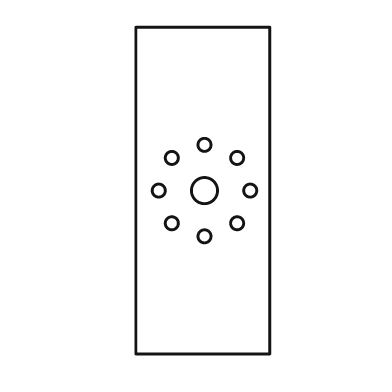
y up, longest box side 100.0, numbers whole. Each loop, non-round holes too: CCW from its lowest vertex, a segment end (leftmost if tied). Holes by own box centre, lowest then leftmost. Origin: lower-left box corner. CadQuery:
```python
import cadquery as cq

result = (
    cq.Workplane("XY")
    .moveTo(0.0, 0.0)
    .lineTo(41.0, 0.0)
    .lineTo(41.0, 100.0)
    .lineTo(0.0, 100.0)
    .close()
    .moveTo(21.0, 36.0)
    .circle(2.0)
    .moveTo(11.0, 40.0)
    .circle(2.0)
    .moveTo(31.0, 40.0)
    .circle(2.0)
    .moveTo(7.0, 50.0)
    .circle(2.0)
    .moveTo(21.0, 50.0)
    .circle(4.0)
    .moveTo(35.0, 50.0)
    .circle(2.0)
    .moveTo(11.0, 60.0)
    .circle(2.0)
    .moveTo(31.0, 60.0)
    .circle(2.0)
    .moveTo(21.0, 64.0)
    .circle(2.0)
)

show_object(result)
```